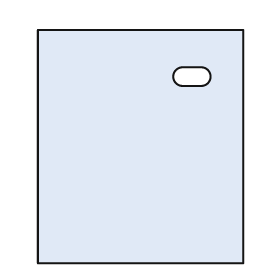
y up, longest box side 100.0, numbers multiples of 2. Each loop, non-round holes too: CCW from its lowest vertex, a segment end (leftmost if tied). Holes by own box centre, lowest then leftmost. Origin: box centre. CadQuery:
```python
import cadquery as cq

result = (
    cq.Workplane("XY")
    .moveTo(-44.0, -50.0)
    .lineTo(44.0, -50.0)
    .lineTo(44.0, 50.0)
    .lineTo(-44.0, 50.0)
    .close()
    .moveTo(18.0, 26.0)
    .lineTo(26.0, 26.0)
    .threePointArc((30.0, 30.0), (26.0, 34.0))
    .lineTo(18.0, 34.0)
    .threePointArc((14.0, 30.0), (18.0, 26.0))
    .close()
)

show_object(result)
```